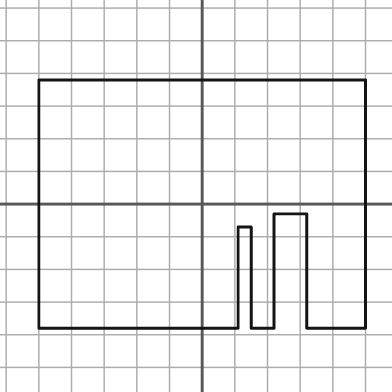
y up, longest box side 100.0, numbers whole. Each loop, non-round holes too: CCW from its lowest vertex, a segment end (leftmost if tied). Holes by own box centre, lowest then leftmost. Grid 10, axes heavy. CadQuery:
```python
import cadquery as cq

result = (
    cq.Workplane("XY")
    .moveTo(-50.0, -38.0)
    .lineTo(11.0, -38.0)
    .lineTo(11.0, -7.0)
    .lineTo(15.0, -7.0)
    .lineTo(15.0, -38.0)
    .lineTo(22.0, -38.0)
    .lineTo(22.0, -3.0)
    .lineTo(32.0, -3.0)
    .lineTo(32.0, -38.0)
    .lineTo(50.0, -38.0)
    .lineTo(50.0, 38.0)
    .lineTo(-50.0, 38.0)
    .close()
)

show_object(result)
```